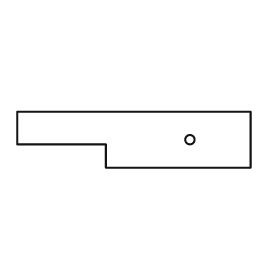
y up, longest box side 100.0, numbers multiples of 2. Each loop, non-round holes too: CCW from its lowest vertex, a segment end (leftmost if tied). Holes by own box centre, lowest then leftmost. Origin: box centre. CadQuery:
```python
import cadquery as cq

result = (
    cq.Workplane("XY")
    .moveTo(-12.0, -12.0)
    .lineTo(50.0, -12.0)
    .lineTo(50.0, 12.0)
    .lineTo(-50.0, 12.0)
    .lineTo(-50.0, -2.0)
    .lineTo(-12.0, -2.0)
    .close()
    .moveTo(24.0, 0.0)
    .circle(2.0)
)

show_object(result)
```